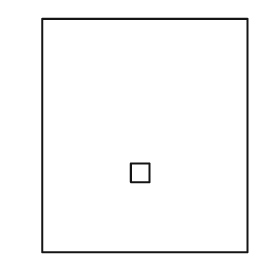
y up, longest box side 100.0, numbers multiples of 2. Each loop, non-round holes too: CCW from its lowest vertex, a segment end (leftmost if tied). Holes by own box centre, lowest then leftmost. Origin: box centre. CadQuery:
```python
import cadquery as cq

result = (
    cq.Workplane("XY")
    .moveTo(-44.0, -50.0)
    .lineTo(44.0, -50.0)
    .lineTo(44.0, 50.0)
    .lineTo(-44.0, 50.0)
    .close()
    .moveTo(-6.0, -20.0)
    .lineTo(2.0, -20.0)
    .lineTo(2.0, -12.0)
    .lineTo(-6.0, -12.0)
    .close()
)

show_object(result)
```